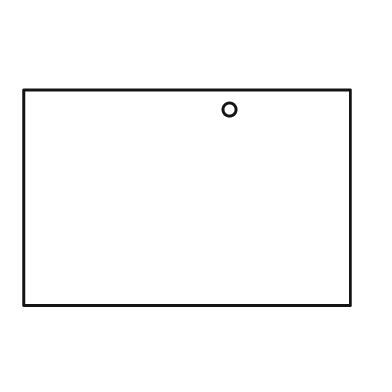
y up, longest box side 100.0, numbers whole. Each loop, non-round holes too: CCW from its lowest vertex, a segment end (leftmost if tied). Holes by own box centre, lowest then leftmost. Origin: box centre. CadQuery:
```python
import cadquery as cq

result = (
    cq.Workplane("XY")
    .moveTo(-50.0, -33.0)
    .lineTo(50.0, -33.0)
    .lineTo(50.0, 33.0)
    .lineTo(-50.0, 33.0)
    .close()
    .moveTo(13.0, 27.0)
    .circle(2.0)
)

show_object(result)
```